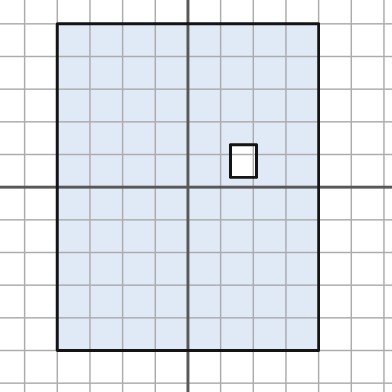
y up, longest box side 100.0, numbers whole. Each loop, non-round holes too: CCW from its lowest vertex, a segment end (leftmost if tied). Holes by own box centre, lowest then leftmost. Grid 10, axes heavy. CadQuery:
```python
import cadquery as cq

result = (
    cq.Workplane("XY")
    .moveTo(-40.0, -50.0)
    .lineTo(40.0, -50.0)
    .lineTo(40.0, 50.0)
    .lineTo(-40.0, 50.0)
    .close()
    .moveTo(13.0, 3.0)
    .lineTo(21.0, 3.0)
    .lineTo(21.0, 13.0)
    .lineTo(13.0, 13.0)
    .close()
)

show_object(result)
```